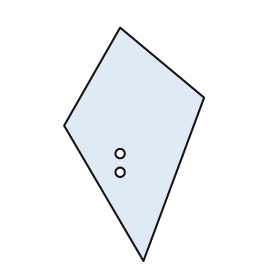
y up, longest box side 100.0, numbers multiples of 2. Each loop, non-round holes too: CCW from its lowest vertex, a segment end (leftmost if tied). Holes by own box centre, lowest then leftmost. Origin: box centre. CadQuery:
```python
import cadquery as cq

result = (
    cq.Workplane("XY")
    .moveTo(4.0, -50.0)
    .lineTo(30.0, 20.0)
    .lineTo(-6.0, 50.0)
    .lineTo(-30.0, 8.0)
    .close()
    .moveTo(-6.0, -12.0)
    .circle(2.0)
    .moveTo(-6.0, -4.0)
    .circle(2.0)
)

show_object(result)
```